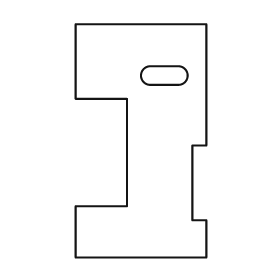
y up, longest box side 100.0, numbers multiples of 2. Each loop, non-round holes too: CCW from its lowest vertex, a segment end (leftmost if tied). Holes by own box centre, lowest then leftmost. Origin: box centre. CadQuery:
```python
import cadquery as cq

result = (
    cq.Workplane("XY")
    .moveTo(-28.0, -50.0)
    .lineTo(28.0, -50.0)
    .lineTo(28.0, -34.0)
    .lineTo(22.0, -34.0)
    .lineTo(22.0, -2.0)
    .lineTo(28.0, -2.0)
    .lineTo(28.0, 50.0)
    .lineTo(-28.0, 50.0)
    .lineTo(-28.0, 18.0)
    .lineTo(-6.0, 18.0)
    .lineTo(-6.0, -28.0)
    .lineTo(-28.0, -28.0)
    .close()
    .moveTo(4.0, 24.0)
    .lineTo(16.0, 24.0)
    .threePointArc((20.0, 28.0), (16.0, 32.0))
    .lineTo(4.0, 32.0)
    .threePointArc((0.0, 28.0), (4.0, 24.0))
    .close()
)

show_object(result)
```